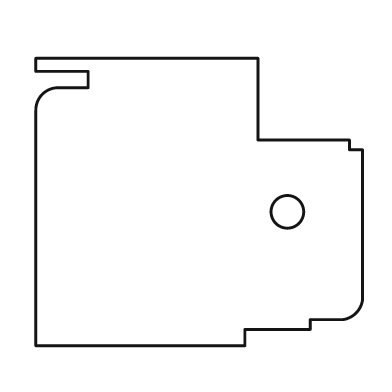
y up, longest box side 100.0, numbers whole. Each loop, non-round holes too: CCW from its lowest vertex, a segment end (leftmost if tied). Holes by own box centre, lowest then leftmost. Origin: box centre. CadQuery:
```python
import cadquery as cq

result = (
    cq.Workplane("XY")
    .moveTo(-50.0, -44.0)
    .lineTo(14.0, -44.0)
    .lineTo(14.0, -39.0)
    .lineTo(34.0, -39.0)
    .lineTo(34.0, -36.0)
    .lineTo(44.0, -36.0)
    .threePointArc((48.0, -34.0), (50.0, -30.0))
    .lineTo(50.0, 16.0)
    .lineTo(46.0, 16.0)
    .lineTo(46.0, 19.0)
    .lineTo(18.0, 19.0)
    .lineTo(18.0, 44.0)
    .lineTo(-50.0, 44.0)
    .lineTo(-50.0, 40.0)
    .lineTo(-34.0, 40.0)
    .lineTo(-34.0, 35.0)
    .lineTo(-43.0, 35.0)
    .threePointArc((-48.0, 33.0), (-50.0, 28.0))
    .close()
    .moveTo(27.0, -3.0)
    .circle(5.0)
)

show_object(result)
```